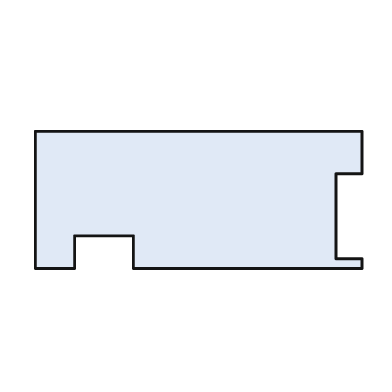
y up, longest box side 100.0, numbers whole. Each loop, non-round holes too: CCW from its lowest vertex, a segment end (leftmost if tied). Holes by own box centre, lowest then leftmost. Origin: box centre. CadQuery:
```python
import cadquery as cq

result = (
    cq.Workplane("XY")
    .moveTo(-50.0, -21.0)
    .lineTo(-38.0, -21.0)
    .lineTo(-38.0, -11.0)
    .lineTo(-20.0, -11.0)
    .lineTo(-20.0, -21.0)
    .lineTo(50.0, -21.0)
    .lineTo(50.0, -18.0)
    .lineTo(42.0, -18.0)
    .lineTo(42.0, 8.0)
    .lineTo(50.0, 8.0)
    .lineTo(50.0, 21.0)
    .lineTo(-50.0, 21.0)
    .close()
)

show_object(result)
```